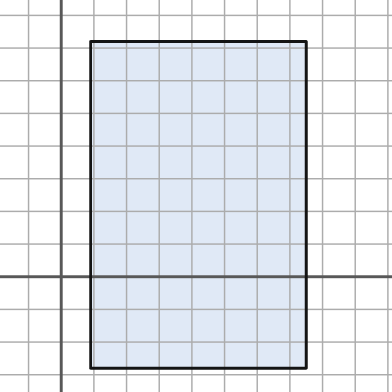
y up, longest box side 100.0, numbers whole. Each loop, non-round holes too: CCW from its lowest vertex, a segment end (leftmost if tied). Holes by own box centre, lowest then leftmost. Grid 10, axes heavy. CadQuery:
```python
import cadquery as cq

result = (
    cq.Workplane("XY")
    .moveTo(9.0, -28.0)
    .lineTo(75.0, -28.0)
    .lineTo(75.0, 72.0)
    .lineTo(9.0, 72.0)
    .close()
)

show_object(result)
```